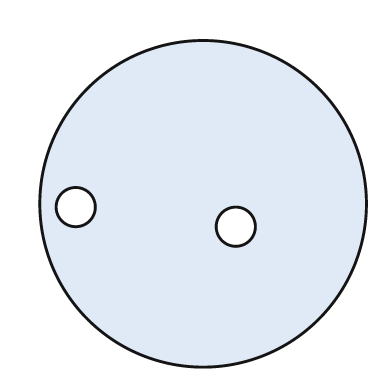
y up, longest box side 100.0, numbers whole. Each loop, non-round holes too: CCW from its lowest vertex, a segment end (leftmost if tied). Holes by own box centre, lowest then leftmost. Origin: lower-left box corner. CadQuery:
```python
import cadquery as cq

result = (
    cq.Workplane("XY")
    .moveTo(50.0, 50.0)
    .circle(50.0)
    .moveTo(60.0, 43.0)
    .circle(6.0)
    .moveTo(11.0, 49.0)
    .circle(6.0)
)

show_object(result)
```